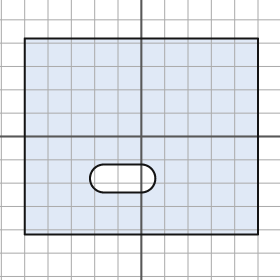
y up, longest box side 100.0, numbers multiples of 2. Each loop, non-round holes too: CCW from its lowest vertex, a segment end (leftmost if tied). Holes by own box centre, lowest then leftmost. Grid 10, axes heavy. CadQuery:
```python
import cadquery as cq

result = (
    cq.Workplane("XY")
    .moveTo(-50.0, -42.0)
    .lineTo(50.0, -42.0)
    .lineTo(50.0, 42.0)
    .lineTo(-50.0, 42.0)
    .close()
    .moveTo(-16.0, -24.0)
    .lineTo(0.0, -24.0)
    .threePointArc((6.0, -18.0), (0.0, -12.0))
    .lineTo(-16.0, -12.0)
    .threePointArc((-22.0, -18.0), (-16.0, -24.0))
    .close()
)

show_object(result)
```